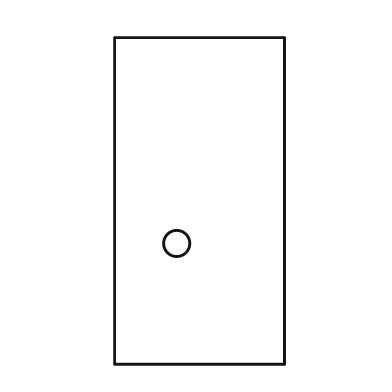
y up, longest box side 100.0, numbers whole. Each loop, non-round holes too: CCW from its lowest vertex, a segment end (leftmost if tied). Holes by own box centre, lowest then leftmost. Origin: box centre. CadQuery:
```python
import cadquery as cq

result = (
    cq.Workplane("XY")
    .moveTo(-26.0, -50.0)
    .lineTo(26.0, -50.0)
    .lineTo(26.0, 50.0)
    .lineTo(-26.0, 50.0)
    .close()
    .moveTo(-7.0, -13.0)
    .circle(4.0)
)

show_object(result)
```